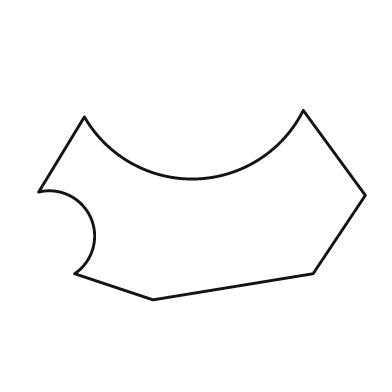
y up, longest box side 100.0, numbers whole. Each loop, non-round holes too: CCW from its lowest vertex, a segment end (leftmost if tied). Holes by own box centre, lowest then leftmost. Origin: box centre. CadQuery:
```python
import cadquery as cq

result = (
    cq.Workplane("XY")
    .moveTo(-15.0, -29.0)
    .lineTo(34.0, -21.0)
    .lineTo(50.0, 3.0)
    .lineTo(31.0, 29.0)
    .threePointArc((-2.0, 8.0), (-36.0, 27.0))
    .lineTo(-50.0, 4.0)
    .threePointArc((-34.0, -4.0), (-39.0, -21.0))
    .close()
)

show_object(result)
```